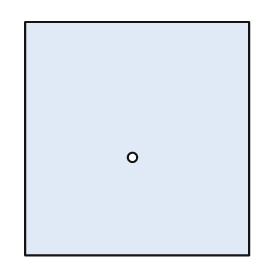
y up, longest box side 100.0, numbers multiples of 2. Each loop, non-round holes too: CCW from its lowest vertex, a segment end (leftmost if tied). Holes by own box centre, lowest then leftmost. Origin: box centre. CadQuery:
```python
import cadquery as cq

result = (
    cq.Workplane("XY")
    .moveTo(-48.0, -50.0)
    .lineTo(48.0, -50.0)
    .lineTo(48.0, 50.0)
    .lineTo(-48.0, 50.0)
    .close()
    .moveTo(-2.0, -8.0)
    .circle(2.0)
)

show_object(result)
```